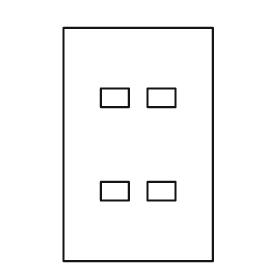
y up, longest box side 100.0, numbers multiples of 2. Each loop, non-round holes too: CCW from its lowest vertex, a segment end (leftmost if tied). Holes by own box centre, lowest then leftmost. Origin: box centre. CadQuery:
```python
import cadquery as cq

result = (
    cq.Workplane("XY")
    .moveTo(-32.0, -50.0)
    .lineTo(32.0, -50.0)
    .lineTo(32.0, 50.0)
    .lineTo(-32.0, 50.0)
    .close()
    .moveTo(-16.0, -24.0)
    .lineTo(-4.0, -24.0)
    .lineTo(-4.0, -16.0)
    .lineTo(-16.0, -16.0)
    .close()
    .moveTo(4.0, -24.0)
    .lineTo(16.0, -24.0)
    .lineTo(16.0, -16.0)
    .lineTo(4.0, -16.0)
    .close()
    .moveTo(-16.0, 16.0)
    .lineTo(-4.0, 16.0)
    .lineTo(-4.0, 24.0)
    .lineTo(-16.0, 24.0)
    .close()
    .moveTo(4.0, 16.0)
    .lineTo(16.0, 16.0)
    .lineTo(16.0, 24.0)
    .lineTo(4.0, 24.0)
    .close()
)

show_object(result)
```